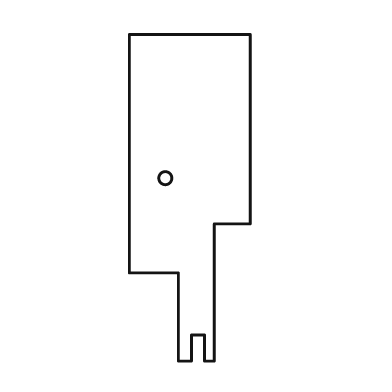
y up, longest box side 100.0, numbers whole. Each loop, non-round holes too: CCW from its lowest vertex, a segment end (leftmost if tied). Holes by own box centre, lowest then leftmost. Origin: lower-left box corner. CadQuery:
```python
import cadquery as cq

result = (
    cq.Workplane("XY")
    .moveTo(15.0, 0.0)
    .lineTo(19.0, 0.0)
    .lineTo(19.0, 8.0)
    .lineTo(23.0, 8.0)
    .lineTo(23.0, 0.0)
    .lineTo(26.0, 0.0)
    .lineTo(26.0, 42.0)
    .lineTo(37.0, 42.0)
    .lineTo(37.0, 100.0)
    .lineTo(0.0, 100.0)
    .lineTo(0.0, 27.0)
    .lineTo(15.0, 27.0)
    .close()
    .moveTo(11.0, 56.0)
    .circle(2.0)
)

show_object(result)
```